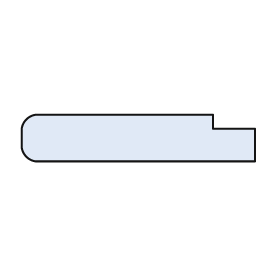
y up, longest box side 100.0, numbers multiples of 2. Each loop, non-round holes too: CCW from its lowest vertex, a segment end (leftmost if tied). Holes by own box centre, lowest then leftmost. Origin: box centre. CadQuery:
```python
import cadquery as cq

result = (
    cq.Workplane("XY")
    .moveTo(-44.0, -10.0)
    .lineTo(50.0, -10.0)
    .lineTo(50.0, 4.0)
    .lineTo(32.0, 4.0)
    .lineTo(32.0, 10.0)
    .lineTo(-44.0, 10.0)
    .threePointArc((-48.0, 8.0), (-50.0, 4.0))
    .lineTo(-50.0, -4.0)
    .threePointArc((-48.0, -8.0), (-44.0, -10.0))
    .close()
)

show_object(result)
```